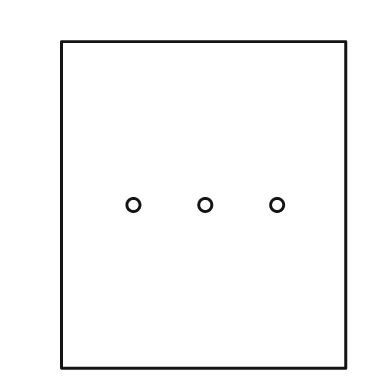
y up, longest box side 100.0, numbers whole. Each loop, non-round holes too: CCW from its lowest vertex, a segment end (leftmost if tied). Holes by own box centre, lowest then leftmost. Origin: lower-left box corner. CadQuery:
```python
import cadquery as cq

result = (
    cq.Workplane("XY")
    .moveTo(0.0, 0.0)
    .lineTo(87.0, 0.0)
    .lineTo(87.0, 100.0)
    .lineTo(0.0, 100.0)
    .close()
    .moveTo(22.0, 50.0)
    .circle(2.0)
    .moveTo(44.0, 50.0)
    .circle(2.0)
    .moveTo(66.0, 50.0)
    .circle(2.0)
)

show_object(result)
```